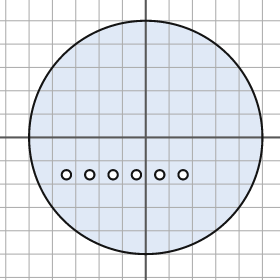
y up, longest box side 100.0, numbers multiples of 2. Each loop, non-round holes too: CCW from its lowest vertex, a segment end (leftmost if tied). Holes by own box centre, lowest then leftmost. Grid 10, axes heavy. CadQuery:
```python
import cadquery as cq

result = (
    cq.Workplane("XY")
    .moveTo(0.0, 0.0)
    .circle(50.0)
    .moveTo(-34.0, -16.0)
    .circle(2.0)
    .moveTo(-24.0, -16.0)
    .circle(2.0)
    .moveTo(-14.0, -16.0)
    .circle(2.0)
    .moveTo(-4.0, -16.0)
    .circle(2.0)
    .moveTo(6.0, -16.0)
    .circle(2.0)
    .moveTo(16.0, -16.0)
    .circle(2.0)
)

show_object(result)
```